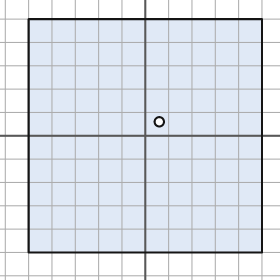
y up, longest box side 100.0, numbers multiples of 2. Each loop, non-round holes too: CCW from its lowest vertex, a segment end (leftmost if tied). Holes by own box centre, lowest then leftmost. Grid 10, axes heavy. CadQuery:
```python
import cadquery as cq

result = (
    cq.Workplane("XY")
    .moveTo(-50.0, -50.0)
    .lineTo(50.0, -50.0)
    .lineTo(50.0, 50.0)
    .lineTo(-50.0, 50.0)
    .close()
    .moveTo(6.0, 6.0)
    .circle(2.0)
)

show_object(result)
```